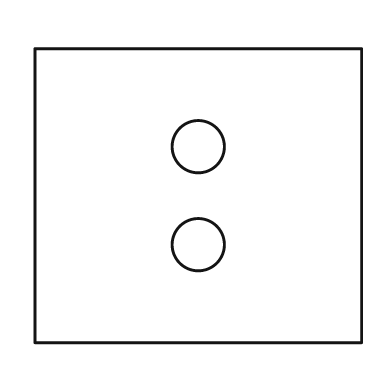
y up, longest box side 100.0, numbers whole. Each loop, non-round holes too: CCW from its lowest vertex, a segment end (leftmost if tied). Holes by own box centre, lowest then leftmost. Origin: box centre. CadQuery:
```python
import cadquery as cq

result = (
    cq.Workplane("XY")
    .moveTo(-50.0, -45.0)
    .lineTo(50.0, -45.0)
    .lineTo(50.0, 45.0)
    .lineTo(-50.0, 45.0)
    .close()
    .moveTo(0.0, -15.0)
    .circle(8.0)
    .moveTo(0.0, 15.0)
    .circle(8.0)
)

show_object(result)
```